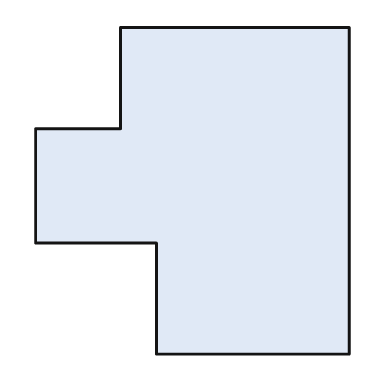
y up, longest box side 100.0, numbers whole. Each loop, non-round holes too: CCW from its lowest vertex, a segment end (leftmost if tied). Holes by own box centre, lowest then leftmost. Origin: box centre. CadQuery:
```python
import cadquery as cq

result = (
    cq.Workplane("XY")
    .moveTo(-11.0, -50.0)
    .lineTo(48.0, -50.0)
    .lineTo(48.0, 50.0)
    .lineTo(-22.0, 50.0)
    .lineTo(-22.0, 19.0)
    .lineTo(-48.0, 19.0)
    .lineTo(-48.0, -16.0)
    .lineTo(-11.0, -16.0)
    .close()
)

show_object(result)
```